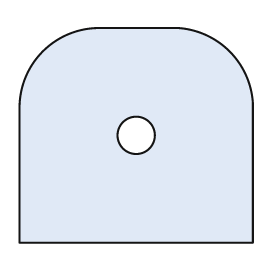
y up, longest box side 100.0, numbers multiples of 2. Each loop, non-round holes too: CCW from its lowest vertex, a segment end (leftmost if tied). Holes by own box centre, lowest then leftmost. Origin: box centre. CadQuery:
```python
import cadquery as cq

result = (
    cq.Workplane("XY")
    .moveTo(-50.0, -46.0)
    .lineTo(50.0, -46.0)
    .lineTo(50.0, 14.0)
    .threePointArc((40.0, 36.0), (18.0, 46.0))
    .lineTo(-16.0, 46.0)
    .threePointArc((-40.0, 36.0), (-50.0, 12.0))
    .close()
    .moveTo(0.0, 0.0)
    .circle(8.0)
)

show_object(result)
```